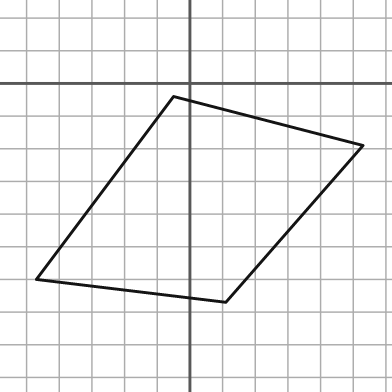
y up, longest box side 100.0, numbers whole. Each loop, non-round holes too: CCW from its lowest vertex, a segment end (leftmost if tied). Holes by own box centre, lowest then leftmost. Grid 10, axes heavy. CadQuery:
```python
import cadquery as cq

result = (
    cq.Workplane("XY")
    .moveTo(11.0, -67.0)
    .lineTo(53.0, -19.0)
    .lineTo(-5.0, -4.0)
    .lineTo(-47.0, -60.0)
    .close()
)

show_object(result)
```